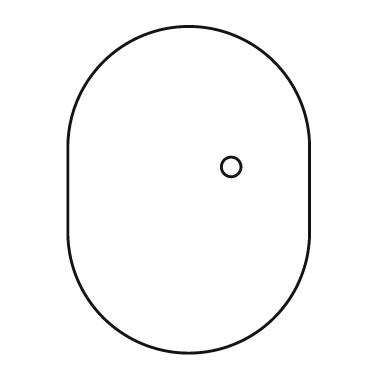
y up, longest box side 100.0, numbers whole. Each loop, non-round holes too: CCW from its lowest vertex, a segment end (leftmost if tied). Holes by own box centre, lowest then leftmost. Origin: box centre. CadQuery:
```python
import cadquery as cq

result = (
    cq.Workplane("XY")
    .moveTo(-37.0, -13.0)
    .threePointArc((0.0, -50.0), (37.0, -13.0))
    .lineTo(37.0, 13.0)
    .threePointArc((0.0, 50.0), (-37.0, 13.0))
    .close()
    .moveTo(13.0, 7.0)
    .circle(3.0)
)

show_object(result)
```